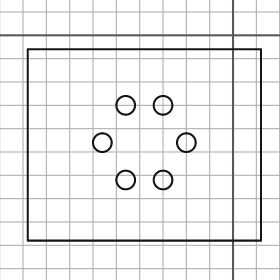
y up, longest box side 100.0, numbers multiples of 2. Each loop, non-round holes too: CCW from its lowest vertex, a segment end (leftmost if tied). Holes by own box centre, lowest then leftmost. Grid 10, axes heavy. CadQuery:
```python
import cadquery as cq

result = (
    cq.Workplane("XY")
    .moveTo(-88.0, -88.0)
    .lineTo(12.0, -88.0)
    .lineTo(12.0, -6.0)
    .lineTo(-88.0, -6.0)
    .close()
    .moveTo(-46.0, -62.0)
    .circle(4.0)
    .moveTo(-30.0, -62.0)
    .circle(4.0)
    .moveTo(-56.0, -46.0)
    .circle(4.0)
    .moveTo(-20.0, -46.0)
    .circle(4.0)
    .moveTo(-46.0, -30.0)
    .circle(4.0)
    .moveTo(-30.0, -30.0)
    .circle(4.0)
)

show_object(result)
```